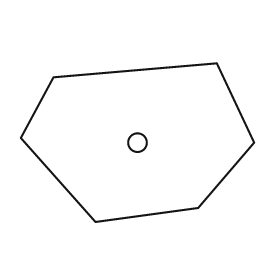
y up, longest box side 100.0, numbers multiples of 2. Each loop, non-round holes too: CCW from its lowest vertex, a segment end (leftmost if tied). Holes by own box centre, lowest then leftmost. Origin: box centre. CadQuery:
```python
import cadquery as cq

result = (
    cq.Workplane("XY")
    .moveTo(-18.0, -34.0)
    .lineTo(26.0, -28.0)
    .lineTo(50.0, 0.0)
    .lineTo(34.0, 34.0)
    .lineTo(-36.0, 28.0)
    .lineTo(-50.0, 2.0)
    .close()
    .moveTo(0.0, 0.0)
    .circle(4.0)
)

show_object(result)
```